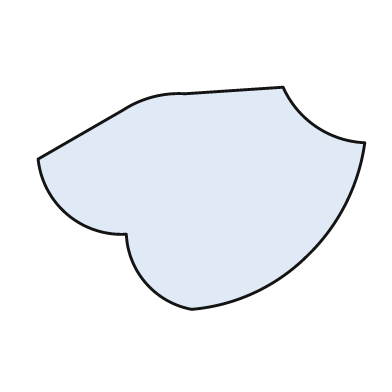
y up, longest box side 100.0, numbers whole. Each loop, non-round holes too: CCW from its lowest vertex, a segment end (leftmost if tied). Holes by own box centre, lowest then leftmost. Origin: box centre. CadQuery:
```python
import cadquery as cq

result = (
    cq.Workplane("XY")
    .moveTo(-3.0, -34.0)
    .threePointArc((16.0, -29.0), (32.0, -18.0))
    .threePointArc((44.0, -2.0), (50.0, 17.0))
    .threePointArc((35.0, 22.0), (25.0, 34.0))
    .lineTo(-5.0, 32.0)
    .threePointArc((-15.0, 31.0), (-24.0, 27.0))
    .lineTo(-50.0, 12.0)
    .threePointArc((-41.0, -5.0), (-23.0, -11.0))
    .threePointArc((-17.0, -26.0), (-3.0, -34.0))
    .close()
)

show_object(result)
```